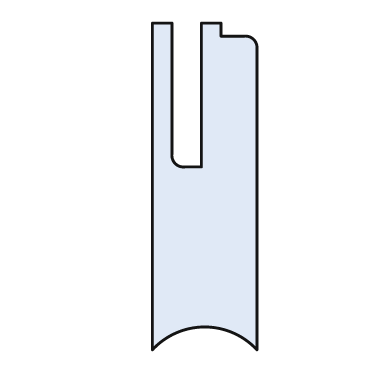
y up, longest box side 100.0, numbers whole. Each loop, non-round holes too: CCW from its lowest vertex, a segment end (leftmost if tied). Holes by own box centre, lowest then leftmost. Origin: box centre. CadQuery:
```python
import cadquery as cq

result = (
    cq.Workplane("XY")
    .moveTo(-16.0, -50.0)
    .threePointArc((0.0, -43.0), (16.0, -50.0))
    .lineTo(16.0, 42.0)
    .threePointArc((15.0, 45.0), (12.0, 46.0))
    .lineTo(5.0, 46.0)
    .lineTo(5.0, 50.0)
    .lineTo(-1.0, 50.0)
    .lineTo(-1.0, 6.0)
    .lineTo(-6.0, 6.0)
    .threePointArc((-9.0, 7.0), (-10.0, 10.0))
    .lineTo(-10.0, 50.0)
    .lineTo(-16.0, 50.0)
    .close()
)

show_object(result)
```